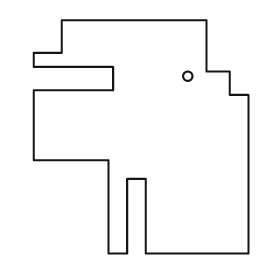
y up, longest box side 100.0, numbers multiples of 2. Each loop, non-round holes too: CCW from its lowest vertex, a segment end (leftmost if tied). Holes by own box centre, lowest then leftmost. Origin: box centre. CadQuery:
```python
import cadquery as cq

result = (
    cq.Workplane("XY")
    .moveTo(-14.0, -50.0)
    .lineTo(-6.0, -50.0)
    .lineTo(-6.0, -18.0)
    .lineTo(2.0, -18.0)
    .lineTo(2.0, -50.0)
    .lineTo(46.0, -50.0)
    .lineTo(46.0, 18.0)
    .lineTo(38.0, 18.0)
    .lineTo(38.0, 28.0)
    .lineTo(28.0, 28.0)
    .lineTo(28.0, 50.0)
    .lineTo(-34.0, 50.0)
    .lineTo(-34.0, 36.0)
    .lineTo(-46.0, 36.0)
    .lineTo(-46.0, 30.0)
    .lineTo(-12.0, 30.0)
    .lineTo(-12.0, 20.0)
    .lineTo(-46.0, 20.0)
    .lineTo(-46.0, -10.0)
    .lineTo(-14.0, -10.0)
    .close()
    .moveTo(20.0, 26.0)
    .circle(2.0)
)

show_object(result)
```